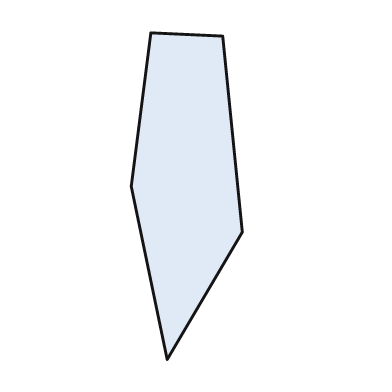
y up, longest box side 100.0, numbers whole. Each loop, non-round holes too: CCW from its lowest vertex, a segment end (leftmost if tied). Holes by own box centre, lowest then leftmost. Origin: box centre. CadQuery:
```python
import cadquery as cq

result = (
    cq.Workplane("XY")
    .moveTo(-6.0, -50.0)
    .lineTo(17.0, -11.0)
    .lineTo(11.0, 49.0)
    .lineTo(-11.0, 50.0)
    .lineTo(-17.0, 3.0)
    .close()
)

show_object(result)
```